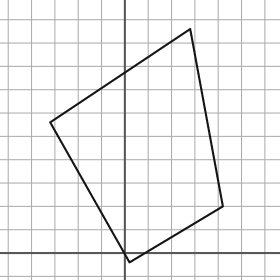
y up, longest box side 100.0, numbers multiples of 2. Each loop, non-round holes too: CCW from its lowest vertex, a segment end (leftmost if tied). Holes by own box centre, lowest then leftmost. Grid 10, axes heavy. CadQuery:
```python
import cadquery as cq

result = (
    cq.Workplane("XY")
    .moveTo(2.0, -4.0)
    .lineTo(42.0, 20.0)
    .lineTo(28.0, 96.0)
    .lineTo(-32.0, 56.0)
    .close()
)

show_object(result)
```